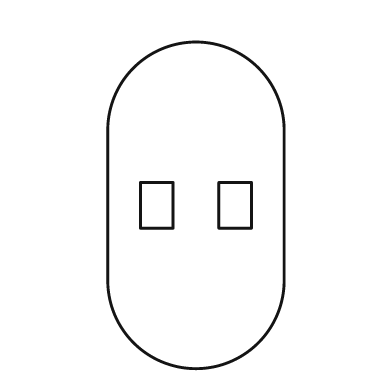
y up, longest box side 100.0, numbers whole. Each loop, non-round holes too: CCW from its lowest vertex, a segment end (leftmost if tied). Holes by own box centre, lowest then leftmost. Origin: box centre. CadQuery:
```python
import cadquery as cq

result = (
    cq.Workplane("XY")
    .moveTo(-27.0, -23.0)
    .threePointArc((0.0, -50.0), (27.0, -23.0))
    .lineTo(27.0, 23.0)
    .threePointArc((0.0, 50.0), (-27.0, 23.0))
    .close()
    .moveTo(-17.0, -7.0)
    .lineTo(-7.0, -7.0)
    .lineTo(-7.0, 7.0)
    .lineTo(-17.0, 7.0)
    .close()
    .moveTo(7.0, -7.0)
    .lineTo(17.0, -7.0)
    .lineTo(17.0, 7.0)
    .lineTo(7.0, 7.0)
    .close()
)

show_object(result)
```